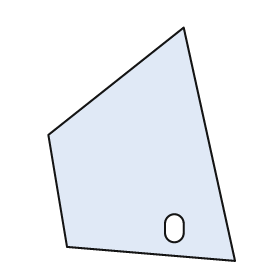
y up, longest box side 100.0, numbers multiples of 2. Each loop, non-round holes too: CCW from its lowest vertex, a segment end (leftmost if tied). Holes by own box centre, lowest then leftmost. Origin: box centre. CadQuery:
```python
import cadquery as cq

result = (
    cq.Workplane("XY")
    .moveTo(40.0, -50.0)
    .lineTo(18.0, 50.0)
    .lineTo(-40.0, 4.0)
    .lineTo(-32.0, -44.0)
    .close()
    .moveTo(10.0, -38.0)
    .threePointArc((14.0, -42.0), (18.0, -38.0))
    .lineTo(18.0, -34.0)
    .threePointArc((14.0, -30.0), (10.0, -34.0))
    .close()
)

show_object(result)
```